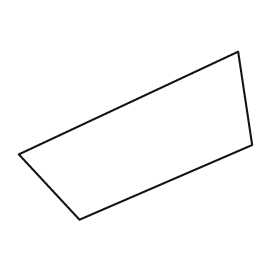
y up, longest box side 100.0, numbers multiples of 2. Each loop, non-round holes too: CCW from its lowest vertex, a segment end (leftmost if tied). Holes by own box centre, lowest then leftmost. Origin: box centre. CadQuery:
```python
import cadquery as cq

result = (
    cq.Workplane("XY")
    .moveTo(-24.0, -36.0)
    .lineTo(50.0, -4.0)
    .lineTo(44.0, 36.0)
    .lineTo(-50.0, -8.0)
    .close()
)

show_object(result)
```